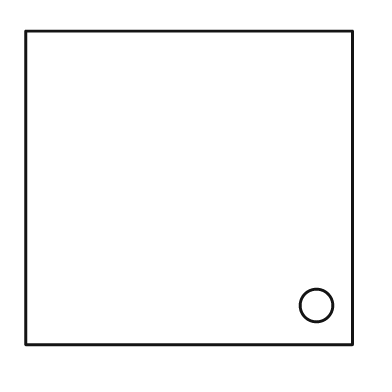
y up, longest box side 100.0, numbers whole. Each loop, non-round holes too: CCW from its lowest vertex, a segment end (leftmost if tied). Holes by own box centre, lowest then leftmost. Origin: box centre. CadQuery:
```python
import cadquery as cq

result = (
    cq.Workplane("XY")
    .moveTo(-50.0, -48.0)
    .lineTo(50.0, -48.0)
    .lineTo(50.0, 48.0)
    .lineTo(-50.0, 48.0)
    .close()
    .moveTo(39.0, -36.0)
    .circle(5.0)
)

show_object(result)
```